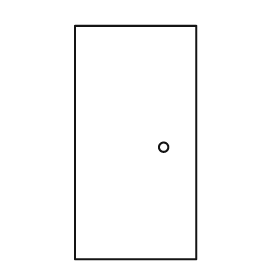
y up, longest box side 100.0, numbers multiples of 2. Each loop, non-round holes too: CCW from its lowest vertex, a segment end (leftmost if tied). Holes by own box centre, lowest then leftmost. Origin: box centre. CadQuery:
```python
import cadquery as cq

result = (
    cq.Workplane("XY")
    .moveTo(-26.0, -50.0)
    .lineTo(26.0, -50.0)
    .lineTo(26.0, 50.0)
    .lineTo(-26.0, 50.0)
    .close()
    .moveTo(12.0, -2.0)
    .circle(2.0)
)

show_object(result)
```